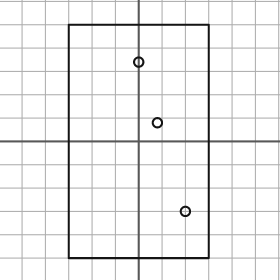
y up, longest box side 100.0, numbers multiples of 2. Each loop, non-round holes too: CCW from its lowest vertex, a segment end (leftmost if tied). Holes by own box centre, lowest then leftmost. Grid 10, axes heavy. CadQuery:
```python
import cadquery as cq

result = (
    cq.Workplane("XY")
    .moveTo(-30.0, -50.0)
    .lineTo(30.0, -50.0)
    .lineTo(30.0, 50.0)
    .lineTo(-30.0, 50.0)
    .close()
    .moveTo(20.0, -30.0)
    .circle(2.0)
    .moveTo(8.0, 8.0)
    .circle(2.0)
    .moveTo(0.0, 34.0)
    .circle(2.0)
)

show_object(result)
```